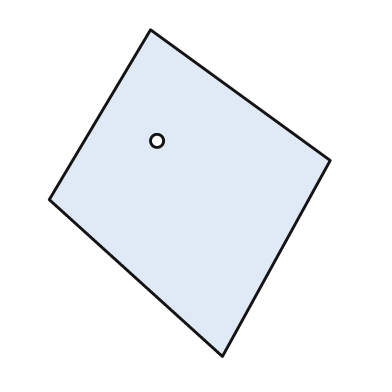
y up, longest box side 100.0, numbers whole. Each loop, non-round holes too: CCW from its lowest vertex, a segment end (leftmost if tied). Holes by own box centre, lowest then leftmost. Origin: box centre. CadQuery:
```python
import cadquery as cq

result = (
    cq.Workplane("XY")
    .moveTo(10.0, -50.0)
    .lineTo(43.0, 10.0)
    .lineTo(-12.0, 50.0)
    .lineTo(-43.0, -2.0)
    .close()
    .moveTo(-10.0, 16.0)
    .circle(2.0)
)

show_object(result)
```